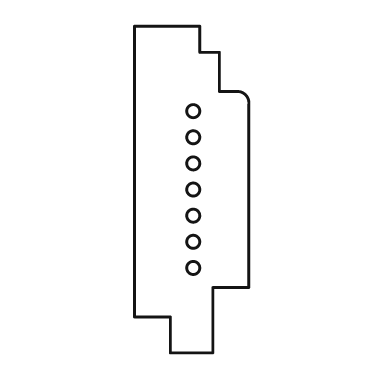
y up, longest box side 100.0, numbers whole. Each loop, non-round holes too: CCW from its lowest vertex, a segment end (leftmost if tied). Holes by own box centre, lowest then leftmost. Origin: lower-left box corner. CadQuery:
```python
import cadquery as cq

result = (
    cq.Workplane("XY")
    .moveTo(11.0, 0.0)
    .lineTo(24.0, 0.0)
    .lineTo(24.0, 20.0)
    .lineTo(35.0, 20.0)
    .lineTo(35.0, 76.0)
    .threePointArc((34.0, 79.0), (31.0, 80.0))
    .lineTo(26.0, 80.0)
    .lineTo(26.0, 92.0)
    .lineTo(20.0, 92.0)
    .lineTo(20.0, 100.0)
    .lineTo(0.0, 100.0)
    .lineTo(0.0, 11.0)
    .lineTo(11.0, 11.0)
    .close()
    .moveTo(18.0, 26.0)
    .circle(2.0)
    .moveTo(18.0, 34.0)
    .circle(2.0)
    .moveTo(18.0, 42.0)
    .circle(2.0)
    .moveTo(18.0, 50.0)
    .circle(2.0)
    .moveTo(18.0, 58.0)
    .circle(2.0)
    .moveTo(18.0, 66.0)
    .circle(2.0)
    .moveTo(18.0, 74.0)
    .circle(2.0)
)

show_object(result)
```